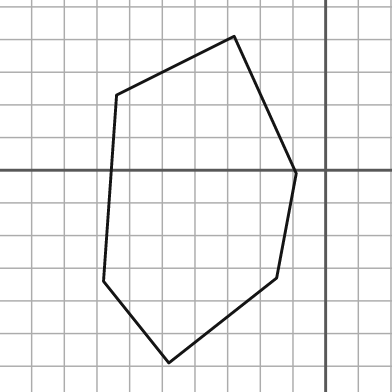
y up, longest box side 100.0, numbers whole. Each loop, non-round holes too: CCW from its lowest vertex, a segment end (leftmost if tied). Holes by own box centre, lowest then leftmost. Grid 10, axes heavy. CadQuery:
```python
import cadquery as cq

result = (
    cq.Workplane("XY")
    .moveTo(-48.0, -59.0)
    .lineTo(-15.0, -33.0)
    .lineTo(-9.0, -1.0)
    .lineTo(-28.0, 41.0)
    .lineTo(-64.0, 23.0)
    .lineTo(-68.0, -34.0)
    .close()
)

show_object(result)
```